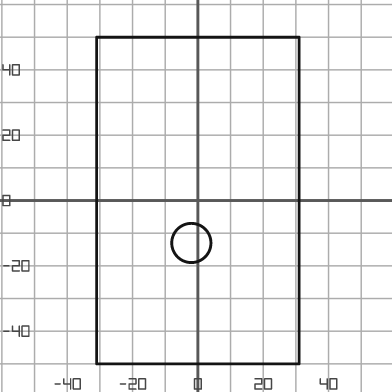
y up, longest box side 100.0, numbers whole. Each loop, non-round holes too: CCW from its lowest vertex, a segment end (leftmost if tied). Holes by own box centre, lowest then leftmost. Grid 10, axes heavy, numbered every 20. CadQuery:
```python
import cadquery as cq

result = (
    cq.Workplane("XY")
    .moveTo(-31.0, -50.0)
    .lineTo(31.0, -50.0)
    .lineTo(31.0, 50.0)
    .lineTo(-31.0, 50.0)
    .close()
    .moveTo(-2.0, -13.0)
    .circle(6.0)
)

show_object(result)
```